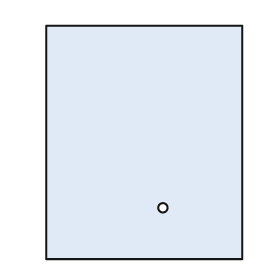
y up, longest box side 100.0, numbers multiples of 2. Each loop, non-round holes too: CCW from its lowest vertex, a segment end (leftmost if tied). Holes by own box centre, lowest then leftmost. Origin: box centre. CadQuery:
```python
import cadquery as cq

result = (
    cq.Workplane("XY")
    .moveTo(-42.0, -50.0)
    .lineTo(42.0, -50.0)
    .lineTo(42.0, 50.0)
    .lineTo(-42.0, 50.0)
    .close()
    .moveTo(8.0, -28.0)
    .circle(2.0)
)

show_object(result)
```